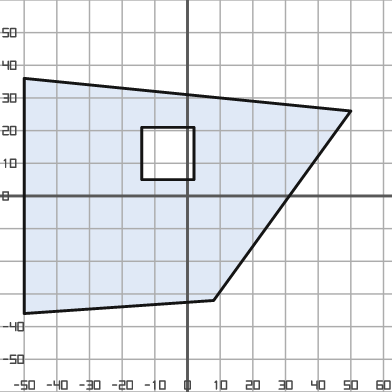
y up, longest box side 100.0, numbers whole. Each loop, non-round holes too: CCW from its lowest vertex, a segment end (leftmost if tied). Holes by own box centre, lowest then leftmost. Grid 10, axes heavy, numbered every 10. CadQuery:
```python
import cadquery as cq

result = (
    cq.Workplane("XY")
    .moveTo(-50.0, -36.0)
    .lineTo(8.0, -32.0)
    .lineTo(50.0, 26.0)
    .lineTo(-50.0, 36.0)
    .close()
    .moveTo(-14.0, 5.0)
    .lineTo(2.0, 5.0)
    .lineTo(2.0, 21.0)
    .lineTo(-14.0, 21.0)
    .close()
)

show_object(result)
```